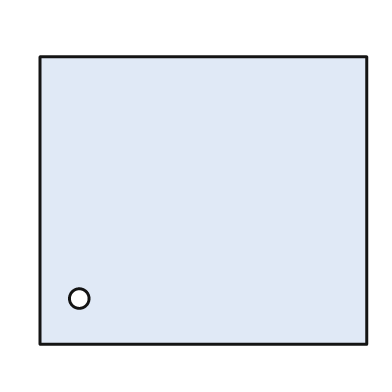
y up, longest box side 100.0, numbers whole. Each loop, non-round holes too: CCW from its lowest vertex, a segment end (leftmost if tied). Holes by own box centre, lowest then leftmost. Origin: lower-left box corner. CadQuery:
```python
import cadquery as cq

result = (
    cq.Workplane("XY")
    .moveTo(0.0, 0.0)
    .lineTo(100.0, 0.0)
    .lineTo(100.0, 88.0)
    .lineTo(0.0, 88.0)
    .close()
    .moveTo(12.0, 14.0)
    .circle(3.0)
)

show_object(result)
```